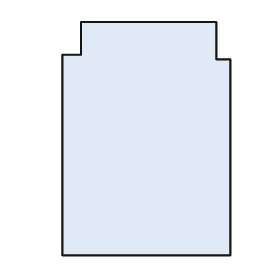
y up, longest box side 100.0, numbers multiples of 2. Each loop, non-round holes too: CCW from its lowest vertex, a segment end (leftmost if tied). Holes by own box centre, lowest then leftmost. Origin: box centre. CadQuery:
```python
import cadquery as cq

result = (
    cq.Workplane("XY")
    .moveTo(-36.0, -50.0)
    .lineTo(36.0, -50.0)
    .lineTo(36.0, 34.0)
    .lineTo(30.0, 34.0)
    .lineTo(30.0, 50.0)
    .lineTo(-28.0, 50.0)
    .lineTo(-28.0, 36.0)
    .lineTo(-36.0, 36.0)
    .close()
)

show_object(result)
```